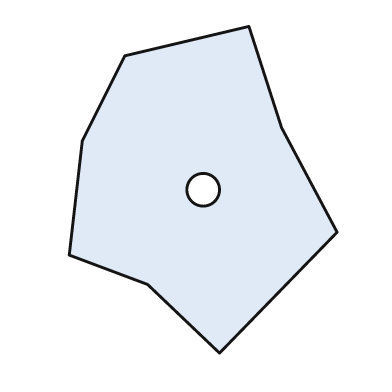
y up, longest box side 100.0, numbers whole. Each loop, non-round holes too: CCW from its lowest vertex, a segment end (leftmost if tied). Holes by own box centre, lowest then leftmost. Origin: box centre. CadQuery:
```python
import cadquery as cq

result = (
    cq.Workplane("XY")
    .moveTo(5.0, -50.0)
    .lineTo(41.0, -13.0)
    .lineTo(24.0, 19.0)
    .lineTo(14.0, 50.0)
    .lineTo(-24.0, 41.0)
    .lineTo(-37.0, 15.0)
    .lineTo(-41.0, -20.0)
    .lineTo(-17.0, -29.0)
    .close()
    .moveTo(0.0, 0.0)
    .circle(5.0)
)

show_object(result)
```